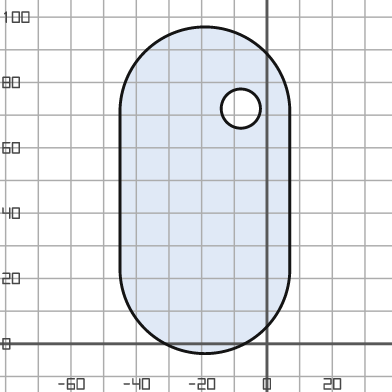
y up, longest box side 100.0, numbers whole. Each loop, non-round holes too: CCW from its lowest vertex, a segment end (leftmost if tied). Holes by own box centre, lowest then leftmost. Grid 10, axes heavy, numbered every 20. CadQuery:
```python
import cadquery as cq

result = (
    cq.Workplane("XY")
    .moveTo(-45.0, 23.0)
    .threePointArc((-19.0, -3.0), (7.0, 23.0))
    .lineTo(7.0, 71.0)
    .threePointArc((-19.0, 97.0), (-45.0, 71.0))
    .close()
    .moveTo(-8.0, 72.0)
    .circle(6.0)
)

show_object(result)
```